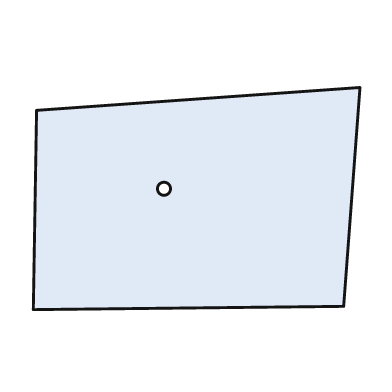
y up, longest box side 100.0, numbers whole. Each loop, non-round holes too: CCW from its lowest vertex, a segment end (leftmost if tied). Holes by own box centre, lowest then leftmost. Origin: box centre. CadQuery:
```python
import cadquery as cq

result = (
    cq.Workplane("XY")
    .moveTo(-50.0, -34.0)
    .lineTo(45.0, -33.0)
    .lineTo(50.0, 34.0)
    .lineTo(-49.0, 27.0)
    .close()
    .moveTo(-10.0, 3.0)
    .circle(2.0)
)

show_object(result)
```